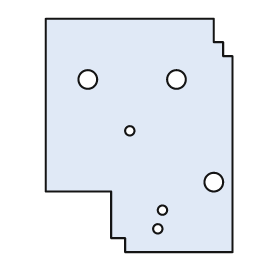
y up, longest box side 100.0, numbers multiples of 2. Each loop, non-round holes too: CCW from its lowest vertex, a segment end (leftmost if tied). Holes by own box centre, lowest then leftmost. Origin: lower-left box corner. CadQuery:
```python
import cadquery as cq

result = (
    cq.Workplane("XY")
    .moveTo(34.0, 0.0)
    .lineTo(80.0, 0.0)
    .lineTo(80.0, 84.0)
    .lineTo(76.0, 84.0)
    .lineTo(76.0, 90.0)
    .lineTo(72.0, 90.0)
    .lineTo(72.0, 100.0)
    .lineTo(0.0, 100.0)
    .lineTo(0.0, 26.0)
    .lineTo(28.0, 26.0)
    .lineTo(28.0, 6.0)
    .lineTo(34.0, 6.0)
    .close()
    .moveTo(48.0, 10.0)
    .circle(2.0)
    .moveTo(50.0, 18.0)
    .circle(2.0)
    .moveTo(72.0, 30.0)
    .circle(4.0)
    .moveTo(36.0, 52.0)
    .circle(2.0)
    .moveTo(18.0, 74.0)
    .circle(4.0)
    .moveTo(56.0, 74.0)
    .circle(4.0)
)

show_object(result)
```